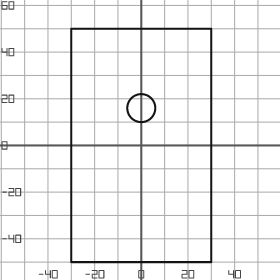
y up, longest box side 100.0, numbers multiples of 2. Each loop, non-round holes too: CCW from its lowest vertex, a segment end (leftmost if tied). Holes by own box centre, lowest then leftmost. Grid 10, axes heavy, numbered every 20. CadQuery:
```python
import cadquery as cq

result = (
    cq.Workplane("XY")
    .moveTo(-30.0, -50.0)
    .lineTo(30.0, -50.0)
    .lineTo(30.0, 50.0)
    .lineTo(-30.0, 50.0)
    .close()
    .moveTo(0.0, 16.0)
    .circle(6.0)
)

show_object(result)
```